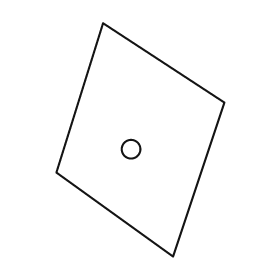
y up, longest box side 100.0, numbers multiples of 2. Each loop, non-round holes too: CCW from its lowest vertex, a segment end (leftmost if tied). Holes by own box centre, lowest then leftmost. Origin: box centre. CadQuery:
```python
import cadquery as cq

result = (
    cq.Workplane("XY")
    .moveTo(14.0, -50.0)
    .lineTo(36.0, 16.0)
    .lineTo(-16.0, 50.0)
    .lineTo(-36.0, -14.0)
    .close()
    .moveTo(-4.0, -4.0)
    .circle(4.0)
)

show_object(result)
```